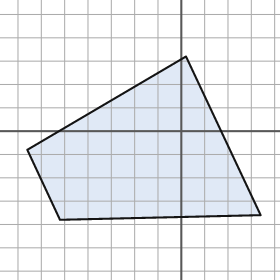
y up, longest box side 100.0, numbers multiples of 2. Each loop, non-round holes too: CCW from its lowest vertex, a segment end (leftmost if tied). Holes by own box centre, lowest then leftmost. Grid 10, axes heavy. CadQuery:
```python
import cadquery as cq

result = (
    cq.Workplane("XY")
    .moveTo(-52.0, -38.0)
    .lineTo(34.0, -36.0)
    .lineTo(2.0, 32.0)
    .lineTo(-66.0, -8.0)
    .close()
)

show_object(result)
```